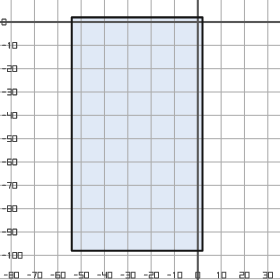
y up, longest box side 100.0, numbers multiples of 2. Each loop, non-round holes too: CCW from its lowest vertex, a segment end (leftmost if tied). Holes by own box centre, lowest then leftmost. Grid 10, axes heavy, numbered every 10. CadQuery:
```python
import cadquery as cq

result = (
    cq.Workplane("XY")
    .moveTo(-54.0, -98.0)
    .lineTo(2.0, -98.0)
    .lineTo(2.0, 2.0)
    .lineTo(-54.0, 2.0)
    .close()
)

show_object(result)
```